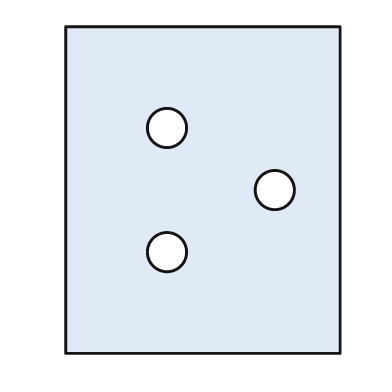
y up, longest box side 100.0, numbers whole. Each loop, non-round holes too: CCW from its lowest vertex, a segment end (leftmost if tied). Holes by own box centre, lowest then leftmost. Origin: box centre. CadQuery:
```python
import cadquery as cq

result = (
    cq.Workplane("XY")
    .moveTo(-42.0, -50.0)
    .lineTo(42.0, -50.0)
    .lineTo(42.0, 50.0)
    .lineTo(-42.0, 50.0)
    .close()
    .moveTo(-11.0, -19.0)
    .circle(6.0)
    .moveTo(22.0, 0.0)
    .circle(6.0)
    .moveTo(-11.0, 19.0)
    .circle(6.0)
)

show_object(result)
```